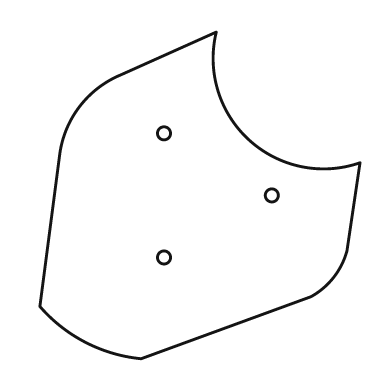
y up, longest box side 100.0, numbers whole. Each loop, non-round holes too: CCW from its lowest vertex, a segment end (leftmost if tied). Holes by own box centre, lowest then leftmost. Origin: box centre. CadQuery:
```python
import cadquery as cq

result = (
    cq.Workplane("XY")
    .moveTo(-18.0, -50.0)
    .lineTo(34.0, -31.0)
    .threePointArc((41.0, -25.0), (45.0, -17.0))
    .lineTo(49.0, 10.0)
    .threePointArc((15.0, 17.0), (5.0, 50.0))
    .lineTo(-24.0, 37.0)
    .threePointArc((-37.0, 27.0), (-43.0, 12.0))
    .lineTo(-49.0, -34.0)
    .threePointArc((-35.0, -45.0), (-18.0, -50.0))
    .close()
    .moveTo(-11.0, -19.0)
    .circle(2.0)
    .moveTo(22.0, 0.0)
    .circle(2.0)
    .moveTo(-11.0, 19.0)
    .circle(2.0)
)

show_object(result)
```